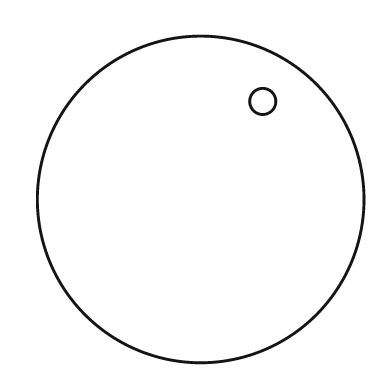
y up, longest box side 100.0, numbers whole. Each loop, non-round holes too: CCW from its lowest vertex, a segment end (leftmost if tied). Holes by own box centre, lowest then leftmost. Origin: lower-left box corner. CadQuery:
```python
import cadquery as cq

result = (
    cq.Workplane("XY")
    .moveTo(50.0, 50.0)
    .circle(50.0)
    .moveTo(69.0, 80.0)
    .circle(4.0)
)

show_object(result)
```